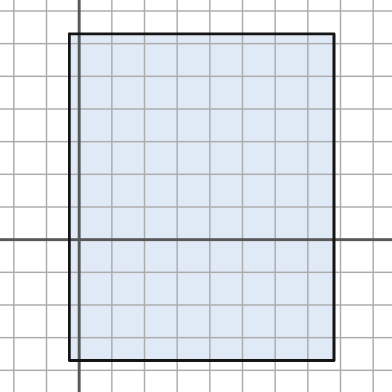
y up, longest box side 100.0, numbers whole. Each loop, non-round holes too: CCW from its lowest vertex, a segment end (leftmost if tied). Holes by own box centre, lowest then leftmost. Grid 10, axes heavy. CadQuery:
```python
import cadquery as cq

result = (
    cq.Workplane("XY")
    .moveTo(-3.0, -37.0)
    .lineTo(78.0, -37.0)
    .lineTo(78.0, 63.0)
    .lineTo(-3.0, 63.0)
    .close()
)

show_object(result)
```